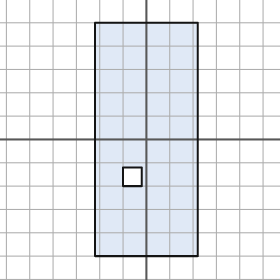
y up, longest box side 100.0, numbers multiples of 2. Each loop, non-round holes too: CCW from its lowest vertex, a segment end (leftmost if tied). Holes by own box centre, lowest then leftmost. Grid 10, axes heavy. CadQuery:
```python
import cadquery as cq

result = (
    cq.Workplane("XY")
    .moveTo(-22.0, -50.0)
    .lineTo(22.0, -50.0)
    .lineTo(22.0, 50.0)
    .lineTo(-22.0, 50.0)
    .close()
    .moveTo(-10.0, -20.0)
    .lineTo(-2.0, -20.0)
    .lineTo(-2.0, -12.0)
    .lineTo(-10.0, -12.0)
    .close()
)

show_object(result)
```